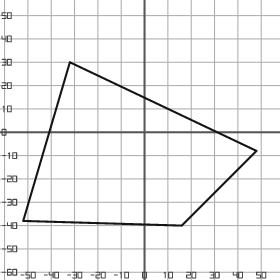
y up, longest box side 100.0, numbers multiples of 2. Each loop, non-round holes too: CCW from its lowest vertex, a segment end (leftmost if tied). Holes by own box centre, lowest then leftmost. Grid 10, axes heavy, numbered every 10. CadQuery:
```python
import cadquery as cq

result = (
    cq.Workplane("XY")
    .moveTo(16.0, -40.0)
    .lineTo(48.0, -8.0)
    .lineTo(-32.0, 30.0)
    .lineTo(-52.0, -38.0)
    .close()
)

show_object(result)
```